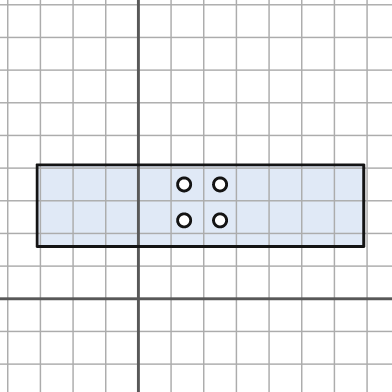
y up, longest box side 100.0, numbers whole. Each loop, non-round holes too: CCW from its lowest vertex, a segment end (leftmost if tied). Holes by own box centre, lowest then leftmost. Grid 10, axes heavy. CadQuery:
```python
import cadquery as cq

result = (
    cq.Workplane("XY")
    .moveTo(-31.0, 16.0)
    .lineTo(69.0, 16.0)
    .lineTo(69.0, 41.0)
    .lineTo(-31.0, 41.0)
    .close()
    .moveTo(14.0, 24.0)
    .circle(2.0)
    .moveTo(25.0, 24.0)
    .circle(2.0)
    .moveTo(14.0, 35.0)
    .circle(2.0)
    .moveTo(25.0, 35.0)
    .circle(2.0)
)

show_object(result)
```